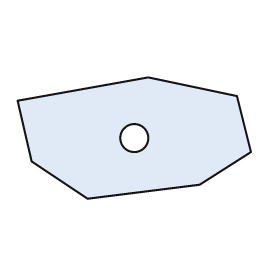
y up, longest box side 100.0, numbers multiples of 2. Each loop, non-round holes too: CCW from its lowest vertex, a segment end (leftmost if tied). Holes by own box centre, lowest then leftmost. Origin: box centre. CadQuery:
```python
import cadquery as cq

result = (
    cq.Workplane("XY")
    .moveTo(-20.0, -26.0)
    .lineTo(28.0, -20.0)
    .lineTo(50.0, -6.0)
    .lineTo(44.0, 18.0)
    .lineTo(6.0, 26.0)
    .lineTo(-50.0, 16.0)
    .lineTo(-44.0, -10.0)
    .close()
    .moveTo(0.0, 0.0)
    .circle(6.0)
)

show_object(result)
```